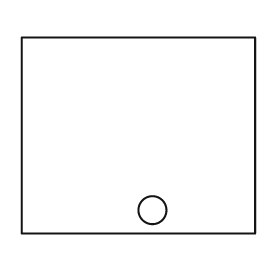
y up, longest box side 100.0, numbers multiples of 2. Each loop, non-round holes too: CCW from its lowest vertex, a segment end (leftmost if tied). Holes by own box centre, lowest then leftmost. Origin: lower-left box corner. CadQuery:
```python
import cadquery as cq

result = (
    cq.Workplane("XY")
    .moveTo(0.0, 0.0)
    .lineTo(100.0, 0.0)
    .lineTo(100.0, 84.0)
    .lineTo(0.0, 84.0)
    .close()
    .moveTo(56.0, 10.0)
    .circle(6.0)
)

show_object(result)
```